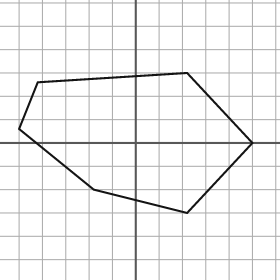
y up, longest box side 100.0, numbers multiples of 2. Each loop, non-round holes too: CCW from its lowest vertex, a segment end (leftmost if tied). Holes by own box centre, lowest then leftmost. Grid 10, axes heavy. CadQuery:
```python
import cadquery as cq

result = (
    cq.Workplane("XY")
    .moveTo(22.0, -30.0)
    .lineTo(50.0, 0.0)
    .lineTo(22.0, 30.0)
    .lineTo(-42.0, 26.0)
    .lineTo(-50.0, 6.0)
    .lineTo(-18.0, -20.0)
    .close()
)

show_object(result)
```